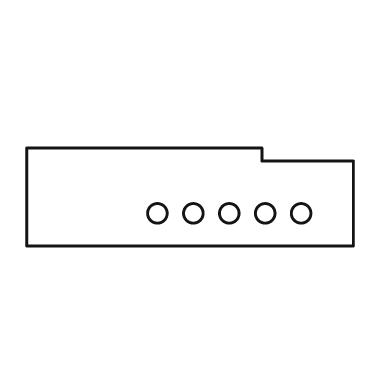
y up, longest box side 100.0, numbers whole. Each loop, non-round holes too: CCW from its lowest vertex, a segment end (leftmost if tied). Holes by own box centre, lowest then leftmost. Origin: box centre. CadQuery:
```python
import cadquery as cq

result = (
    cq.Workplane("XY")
    .moveTo(-50.0, -15.0)
    .lineTo(50.0, -15.0)
    .lineTo(50.0, 11.0)
    .lineTo(22.0, 11.0)
    .lineTo(22.0, 15.0)
    .lineTo(-50.0, 15.0)
    .close()
    .moveTo(-10.0, -5.0)
    .circle(3.0)
    .moveTo(1.0, -5.0)
    .circle(3.0)
    .moveTo(12.0, -5.0)
    .circle(3.0)
    .moveTo(23.0, -5.0)
    .circle(3.0)
    .moveTo(34.0, -5.0)
    .circle(3.0)
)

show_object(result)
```